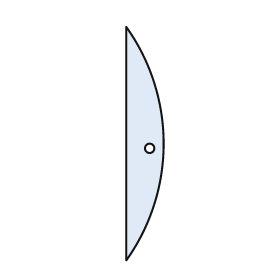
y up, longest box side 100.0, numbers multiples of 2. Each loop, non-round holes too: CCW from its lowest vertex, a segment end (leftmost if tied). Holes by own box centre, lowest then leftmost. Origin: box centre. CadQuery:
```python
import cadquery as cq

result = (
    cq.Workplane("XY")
    .moveTo(-8.0, -50.0)
    .threePointArc((8.0, 0.0), (-8.0, 50.0))
    .close()
    .moveTo(2.0, -2.0)
    .circle(2.0)
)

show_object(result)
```